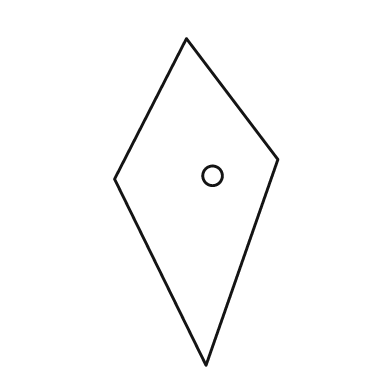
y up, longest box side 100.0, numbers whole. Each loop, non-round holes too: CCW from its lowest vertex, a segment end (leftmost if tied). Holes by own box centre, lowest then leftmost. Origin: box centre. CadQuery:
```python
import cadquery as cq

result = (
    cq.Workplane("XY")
    .moveTo(3.0, -50.0)
    .lineTo(25.0, 13.0)
    .lineTo(-3.0, 50.0)
    .lineTo(-25.0, 7.0)
    .close()
    .moveTo(5.0, 8.0)
    .circle(3.0)
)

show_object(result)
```